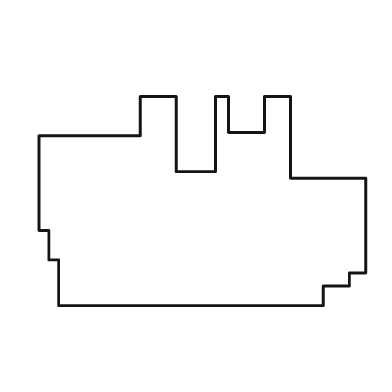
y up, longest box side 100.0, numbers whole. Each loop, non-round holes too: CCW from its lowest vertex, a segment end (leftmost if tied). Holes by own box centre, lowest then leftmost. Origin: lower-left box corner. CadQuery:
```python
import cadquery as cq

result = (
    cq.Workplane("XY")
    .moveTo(6.0, 0.0)
    .lineTo(87.0, 0.0)
    .lineTo(87.0, 6.0)
    .lineTo(95.0, 6.0)
    .lineTo(95.0, 10.0)
    .lineTo(100.0, 10.0)
    .lineTo(100.0, 39.0)
    .lineTo(77.0, 39.0)
    .lineTo(77.0, 64.0)
    .lineTo(69.0, 64.0)
    .lineTo(69.0, 53.0)
    .lineTo(58.0, 53.0)
    .lineTo(58.0, 64.0)
    .lineTo(54.0, 64.0)
    .lineTo(54.0, 41.0)
    .lineTo(42.0, 41.0)
    .lineTo(42.0, 64.0)
    .lineTo(31.0, 64.0)
    .lineTo(31.0, 52.0)
    .lineTo(0.0, 52.0)
    .lineTo(0.0, 23.0)
    .lineTo(3.0, 23.0)
    .lineTo(3.0, 14.0)
    .lineTo(6.0, 14.0)
    .close()
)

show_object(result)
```